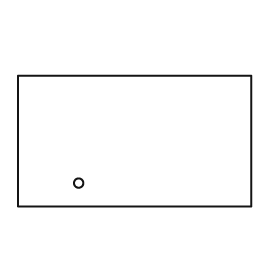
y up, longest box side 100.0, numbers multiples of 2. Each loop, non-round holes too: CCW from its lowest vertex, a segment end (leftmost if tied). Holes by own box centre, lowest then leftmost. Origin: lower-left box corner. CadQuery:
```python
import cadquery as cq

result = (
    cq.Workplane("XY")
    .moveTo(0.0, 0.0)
    .lineTo(100.0, 0.0)
    .lineTo(100.0, 56.0)
    .lineTo(0.0, 56.0)
    .close()
    .moveTo(26.0, 10.0)
    .circle(2.0)
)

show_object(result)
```